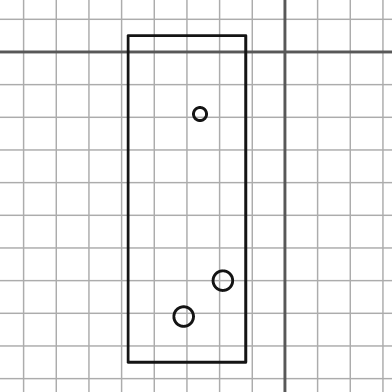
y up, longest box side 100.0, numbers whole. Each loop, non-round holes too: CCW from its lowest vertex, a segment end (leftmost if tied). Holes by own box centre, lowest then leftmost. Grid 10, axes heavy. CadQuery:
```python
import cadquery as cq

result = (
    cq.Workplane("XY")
    .moveTo(-48.0, -95.0)
    .lineTo(-12.0, -95.0)
    .lineTo(-12.0, 5.0)
    .lineTo(-48.0, 5.0)
    .close()
    .moveTo(-31.0, -81.0)
    .circle(3.0)
    .moveTo(-19.0, -70.0)
    .circle(3.0)
    .moveTo(-26.0, -19.0)
    .circle(2.0)
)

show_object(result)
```